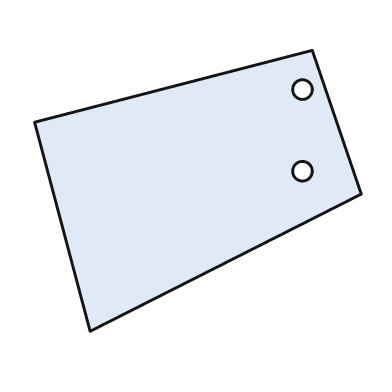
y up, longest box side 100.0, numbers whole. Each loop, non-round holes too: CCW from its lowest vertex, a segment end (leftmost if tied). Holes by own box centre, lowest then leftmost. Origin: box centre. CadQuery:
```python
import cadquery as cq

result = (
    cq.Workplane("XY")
    .moveTo(-33.0, -43.0)
    .lineTo(50.0, -1.0)
    .lineTo(35.0, 43.0)
    .lineTo(-50.0, 21.0)
    .close()
    .moveTo(32.0, 6.0)
    .circle(3.0)
    .moveTo(32.0, 31.0)
    .circle(3.0)
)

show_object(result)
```